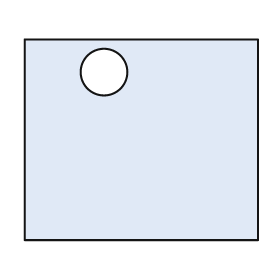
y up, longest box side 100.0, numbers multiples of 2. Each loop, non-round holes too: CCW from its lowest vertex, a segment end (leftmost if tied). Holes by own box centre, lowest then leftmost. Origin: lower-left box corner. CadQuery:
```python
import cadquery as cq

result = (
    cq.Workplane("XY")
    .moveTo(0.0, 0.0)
    .lineTo(100.0, 0.0)
    .lineTo(100.0, 86.0)
    .lineTo(0.0, 86.0)
    .close()
    .moveTo(34.0, 72.0)
    .circle(10.0)
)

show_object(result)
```